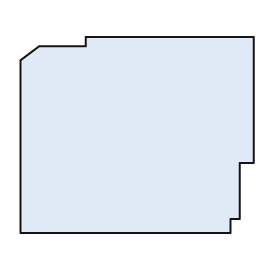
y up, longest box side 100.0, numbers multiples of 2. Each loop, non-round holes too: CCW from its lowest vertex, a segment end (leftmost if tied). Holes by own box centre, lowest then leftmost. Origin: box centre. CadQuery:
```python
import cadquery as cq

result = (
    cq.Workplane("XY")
    .moveTo(-50.0, -42.0)
    .lineTo(40.0, -42.0)
    .lineTo(40.0, -36.0)
    .lineTo(44.0, -36.0)
    .lineTo(44.0, -12.0)
    .lineTo(50.0, -12.0)
    .lineTo(50.0, 42.0)
    .lineTo(-22.0, 42.0)
    .lineTo(-22.0, 38.0)
    .lineTo(-42.0, 38.0)
    .lineTo(-50.0, 32.0)
    .close()
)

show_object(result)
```